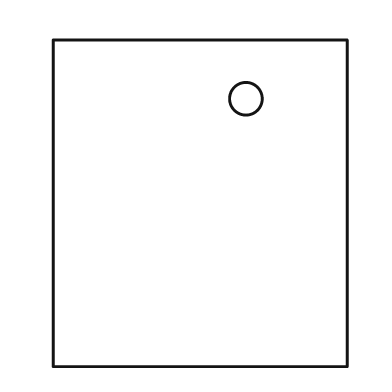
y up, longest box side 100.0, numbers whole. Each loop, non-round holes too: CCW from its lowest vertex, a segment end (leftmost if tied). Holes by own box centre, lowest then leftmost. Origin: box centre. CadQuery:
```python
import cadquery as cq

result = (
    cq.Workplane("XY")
    .moveTo(-45.0, -50.0)
    .lineTo(45.0, -50.0)
    .lineTo(45.0, 50.0)
    .lineTo(-45.0, 50.0)
    .close()
    .moveTo(14.0, 32.0)
    .circle(5.0)
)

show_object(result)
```